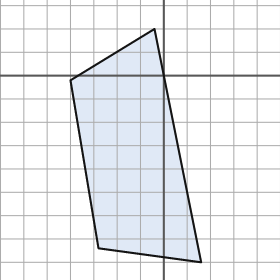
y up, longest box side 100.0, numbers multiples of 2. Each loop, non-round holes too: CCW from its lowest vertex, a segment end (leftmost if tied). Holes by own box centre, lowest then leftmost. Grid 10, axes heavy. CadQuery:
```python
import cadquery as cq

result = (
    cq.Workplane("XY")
    .moveTo(16.0, -80.0)
    .lineTo(-4.0, 20.0)
    .lineTo(-40.0, -2.0)
    .lineTo(-28.0, -74.0)
    .close()
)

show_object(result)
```